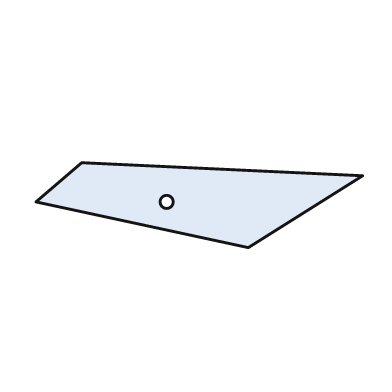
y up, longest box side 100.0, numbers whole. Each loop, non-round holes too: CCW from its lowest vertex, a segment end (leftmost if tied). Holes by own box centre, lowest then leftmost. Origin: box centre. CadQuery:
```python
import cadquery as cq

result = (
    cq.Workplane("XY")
    .moveTo(15.0, -13.0)
    .lineTo(50.0, 9.0)
    .lineTo(-36.0, 13.0)
    .lineTo(-50.0, 1.0)
    .close()
    .moveTo(-10.0, 1.0)
    .circle(2.0)
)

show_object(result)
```